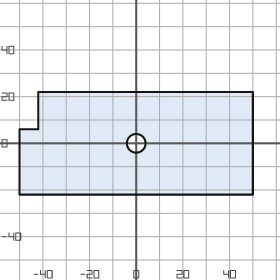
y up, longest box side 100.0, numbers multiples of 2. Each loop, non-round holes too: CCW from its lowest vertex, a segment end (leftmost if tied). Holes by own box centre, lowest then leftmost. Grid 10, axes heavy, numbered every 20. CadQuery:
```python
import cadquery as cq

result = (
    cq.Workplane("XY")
    .moveTo(-50.0, -22.0)
    .lineTo(50.0, -22.0)
    .lineTo(50.0, 22.0)
    .lineTo(-42.0, 22.0)
    .lineTo(-42.0, 6.0)
    .lineTo(-50.0, 6.0)
    .close()
    .moveTo(0.0, 0.0)
    .circle(4.0)
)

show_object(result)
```